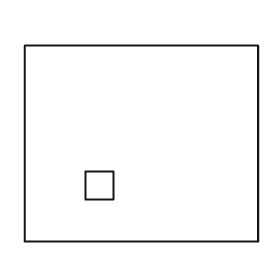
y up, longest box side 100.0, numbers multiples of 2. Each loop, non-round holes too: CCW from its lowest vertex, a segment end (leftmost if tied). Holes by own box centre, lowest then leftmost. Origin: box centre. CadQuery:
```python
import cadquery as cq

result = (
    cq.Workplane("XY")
    .moveTo(-50.0, -42.0)
    .lineTo(50.0, -42.0)
    .lineTo(50.0, 42.0)
    .lineTo(-50.0, 42.0)
    .close()
    .moveTo(-24.0, -24.0)
    .lineTo(-12.0, -24.0)
    .lineTo(-12.0, -12.0)
    .lineTo(-24.0, -12.0)
    .close()
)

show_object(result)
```